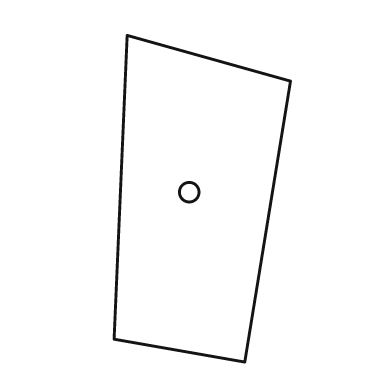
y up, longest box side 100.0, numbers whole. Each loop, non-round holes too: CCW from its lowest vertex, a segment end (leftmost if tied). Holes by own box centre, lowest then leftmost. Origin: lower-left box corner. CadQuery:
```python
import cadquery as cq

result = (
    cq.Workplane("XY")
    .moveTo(40.0, 0.0)
    .lineTo(54.0, 86.0)
    .lineTo(4.0, 100.0)
    .lineTo(0.0, 7.0)
    .close()
    .moveTo(23.0, 52.0)
    .circle(3.0)
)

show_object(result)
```